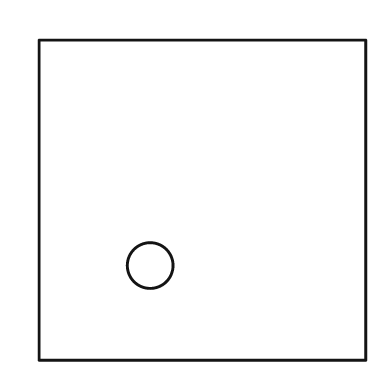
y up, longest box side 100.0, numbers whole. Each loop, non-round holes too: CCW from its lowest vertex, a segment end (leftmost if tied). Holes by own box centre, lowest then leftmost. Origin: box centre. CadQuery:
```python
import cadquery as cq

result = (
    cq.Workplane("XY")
    .moveTo(-50.0, -49.0)
    .lineTo(50.0, -49.0)
    .lineTo(50.0, 49.0)
    .lineTo(-50.0, 49.0)
    .close()
    .moveTo(-16.0, -20.0)
    .circle(7.0)
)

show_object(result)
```